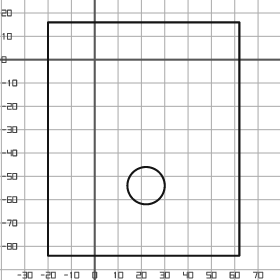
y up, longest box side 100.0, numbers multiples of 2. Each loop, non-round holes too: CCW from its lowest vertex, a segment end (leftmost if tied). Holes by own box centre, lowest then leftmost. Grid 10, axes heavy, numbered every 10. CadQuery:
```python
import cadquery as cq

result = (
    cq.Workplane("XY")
    .moveTo(-20.0, -84.0)
    .lineTo(62.0, -84.0)
    .lineTo(62.0, 16.0)
    .lineTo(-20.0, 16.0)
    .close()
    .moveTo(22.0, -54.0)
    .circle(8.0)
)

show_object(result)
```